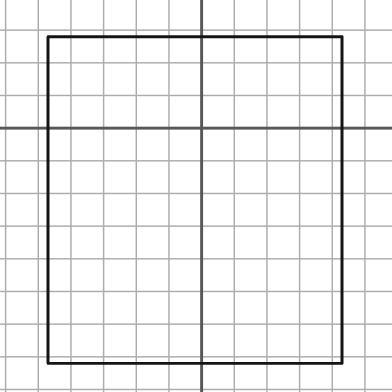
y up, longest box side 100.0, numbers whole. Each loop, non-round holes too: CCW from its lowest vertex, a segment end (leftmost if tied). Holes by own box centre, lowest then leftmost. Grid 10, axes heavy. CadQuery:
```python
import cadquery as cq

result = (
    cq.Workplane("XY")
    .moveTo(-47.0, -72.0)
    .lineTo(43.0, -72.0)
    .lineTo(43.0, 28.0)
    .lineTo(-47.0, 28.0)
    .close()
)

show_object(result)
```